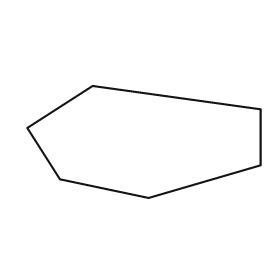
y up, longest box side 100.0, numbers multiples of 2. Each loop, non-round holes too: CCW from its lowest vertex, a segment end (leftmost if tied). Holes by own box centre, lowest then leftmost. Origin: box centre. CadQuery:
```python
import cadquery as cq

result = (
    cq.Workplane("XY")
    .moveTo(2.0, -24.0)
    .lineTo(50.0, -10.0)
    .lineTo(50.0, 14.0)
    .lineTo(-22.0, 24.0)
    .lineTo(-50.0, 6.0)
    .lineTo(-36.0, -16.0)
    .close()
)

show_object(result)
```